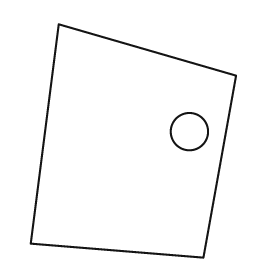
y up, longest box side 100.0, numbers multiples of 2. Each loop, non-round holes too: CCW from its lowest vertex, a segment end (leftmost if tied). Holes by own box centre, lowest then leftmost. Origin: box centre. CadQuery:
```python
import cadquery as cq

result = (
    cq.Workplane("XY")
    .moveTo(30.0, -50.0)
    .lineTo(44.0, 28.0)
    .lineTo(-32.0, 50.0)
    .lineTo(-44.0, -44.0)
    .close()
    .moveTo(24.0, 4.0)
    .circle(8.0)
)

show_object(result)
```